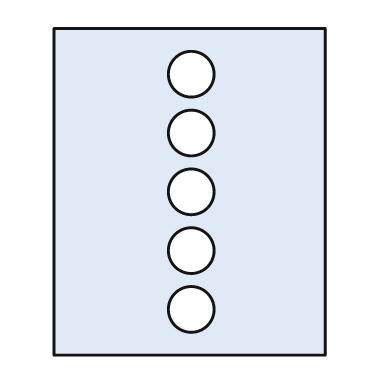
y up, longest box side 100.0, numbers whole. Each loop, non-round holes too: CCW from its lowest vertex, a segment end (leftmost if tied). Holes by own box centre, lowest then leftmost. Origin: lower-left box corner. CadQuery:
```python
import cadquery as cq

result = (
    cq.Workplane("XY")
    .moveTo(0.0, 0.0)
    .lineTo(83.0, 0.0)
    .lineTo(83.0, 100.0)
    .lineTo(0.0, 100.0)
    .close()
    .moveTo(42.0, 14.0)
    .circle(7.0)
    .moveTo(42.0, 32.0)
    .circle(7.0)
    .moveTo(42.0, 50.0)
    .circle(7.0)
    .moveTo(42.0, 68.0)
    .circle(7.0)
    .moveTo(42.0, 86.0)
    .circle(7.0)
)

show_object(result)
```